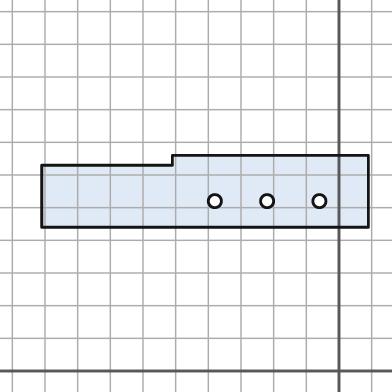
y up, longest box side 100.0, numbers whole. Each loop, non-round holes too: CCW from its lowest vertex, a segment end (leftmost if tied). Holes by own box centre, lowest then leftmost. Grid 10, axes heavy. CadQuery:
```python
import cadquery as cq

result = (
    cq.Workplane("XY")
    .moveTo(-91.0, 44.0)
    .lineTo(9.0, 44.0)
    .lineTo(9.0, 66.0)
    .lineTo(-51.0, 66.0)
    .lineTo(-51.0, 63.0)
    .lineTo(-91.0, 63.0)
    .close()
    .moveTo(-38.0, 52.0)
    .circle(2.0)
    .moveTo(-22.0, 52.0)
    .circle(2.0)
    .moveTo(-6.0, 52.0)
    .circle(2.0)
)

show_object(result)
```